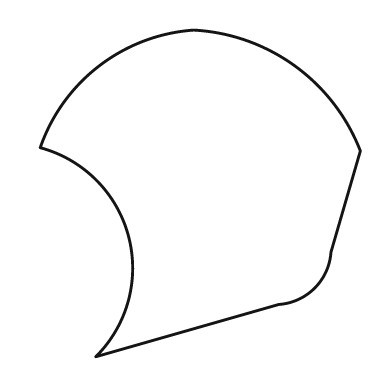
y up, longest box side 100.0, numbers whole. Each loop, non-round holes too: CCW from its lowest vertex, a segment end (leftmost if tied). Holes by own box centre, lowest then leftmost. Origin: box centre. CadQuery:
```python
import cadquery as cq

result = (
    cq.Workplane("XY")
    .moveTo(-32.0, -50.0)
    .lineTo(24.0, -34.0)
    .threePointArc((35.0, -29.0), (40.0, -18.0))
    .lineTo(49.0, 13.0)
    .threePointArc((29.0, 39.0), (-2.0, 50.0))
    .threePointArc((-31.0, 39.0), (-49.0, 14.0))
    .threePointArc((-22.0, -13.0), (-32.0, -50.0))
    .close()
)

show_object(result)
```